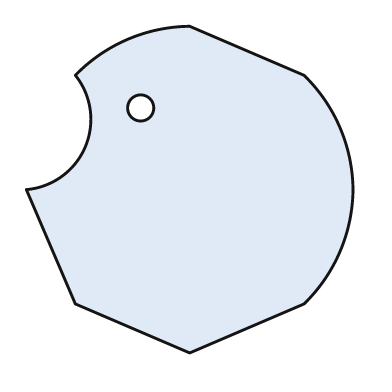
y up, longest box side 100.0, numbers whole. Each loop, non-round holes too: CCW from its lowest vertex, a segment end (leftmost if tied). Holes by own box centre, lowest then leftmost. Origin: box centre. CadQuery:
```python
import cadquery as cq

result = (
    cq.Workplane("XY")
    .moveTo(0.0, -50.0)
    .lineTo(35.0, -35.0)
    .threePointArc((46.0, -19.0), (50.0, 0.0))
    .threePointArc((46.0, 19.0), (35.0, 35.0))
    .lineTo(0.0, 50.0)
    .threePointArc((-19.0, 46.0), (-35.0, 35.0))
    .threePointArc((-32.0, 13.0), (-50.0, 0.0))
    .lineTo(-35.0, -35.0)
    .close()
    .moveTo(-15.0, 25.0)
    .circle(4.0)
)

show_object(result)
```